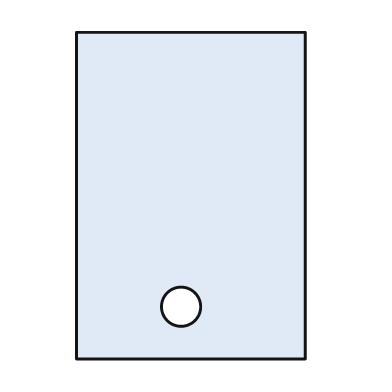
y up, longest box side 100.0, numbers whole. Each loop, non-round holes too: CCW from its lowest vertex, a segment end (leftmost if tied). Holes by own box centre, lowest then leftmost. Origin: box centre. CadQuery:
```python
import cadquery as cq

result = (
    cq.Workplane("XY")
    .moveTo(-35.0, -50.0)
    .lineTo(35.0, -50.0)
    .lineTo(35.0, 50.0)
    .lineTo(-35.0, 50.0)
    .close()
    .moveTo(-3.0, -34.0)
    .circle(6.0)
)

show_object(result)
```